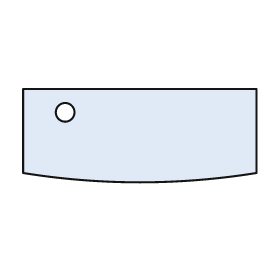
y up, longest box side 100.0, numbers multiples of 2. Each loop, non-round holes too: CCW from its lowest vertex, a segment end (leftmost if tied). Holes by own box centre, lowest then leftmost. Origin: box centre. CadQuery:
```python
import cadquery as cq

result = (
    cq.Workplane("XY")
    .moveTo(-50.0, -16.0)
    .threePointArc((0.0, -20.0), (50.0, -16.0))
    .lineTo(50.0, 20.0)
    .lineTo(-50.0, 20.0)
    .close()
    .moveTo(-32.0, 10.0)
    .circle(4.0)
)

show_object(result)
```